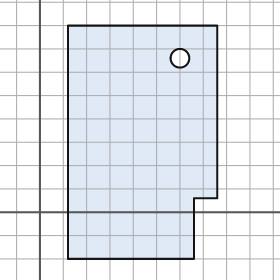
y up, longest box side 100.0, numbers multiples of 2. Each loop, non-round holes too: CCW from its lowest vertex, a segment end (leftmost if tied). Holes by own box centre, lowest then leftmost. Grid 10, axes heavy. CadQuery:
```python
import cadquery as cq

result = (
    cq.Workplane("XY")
    .moveTo(12.0, -20.0)
    .lineTo(66.0, -20.0)
    .lineTo(66.0, 6.0)
    .lineTo(76.0, 6.0)
    .lineTo(76.0, 80.0)
    .lineTo(12.0, 80.0)
    .close()
    .moveTo(60.0, 66.0)
    .circle(4.0)
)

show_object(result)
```